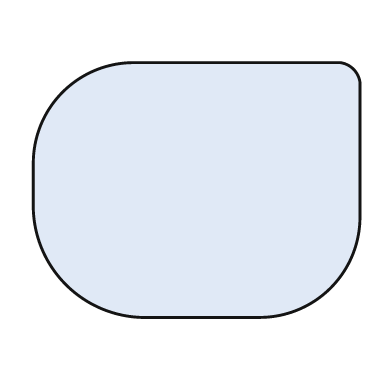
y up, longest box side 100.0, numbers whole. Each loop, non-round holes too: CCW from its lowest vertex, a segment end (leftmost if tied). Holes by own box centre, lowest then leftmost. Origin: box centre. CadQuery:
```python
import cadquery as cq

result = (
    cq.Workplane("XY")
    .moveTo(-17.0, -39.0)
    .lineTo(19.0, -39.0)
    .threePointArc((41.0, -30.0), (50.0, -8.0))
    .lineTo(50.0, 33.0)
    .threePointArc((48.0, 37.0), (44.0, 39.0))
    .lineTo(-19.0, 39.0)
    .threePointArc((-41.0, 30.0), (-50.0, 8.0))
    .lineTo(-50.0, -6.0)
    .threePointArc((-40.0, -29.0), (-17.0, -39.0))
    .close()
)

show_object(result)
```